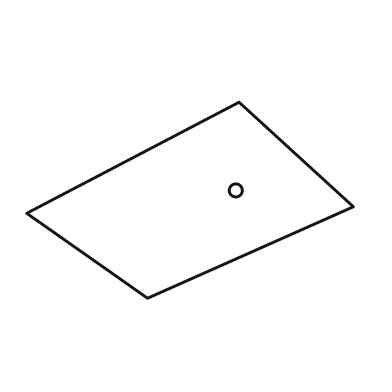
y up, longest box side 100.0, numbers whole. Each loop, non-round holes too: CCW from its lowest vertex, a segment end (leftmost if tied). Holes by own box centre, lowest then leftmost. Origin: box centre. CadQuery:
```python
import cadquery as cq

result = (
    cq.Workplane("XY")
    .moveTo(-13.0, -30.0)
    .lineTo(50.0, -2.0)
    .lineTo(15.0, 30.0)
    .lineTo(-50.0, -4.0)
    .close()
    .moveTo(14.0, 3.0)
    .circle(2.0)
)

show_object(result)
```